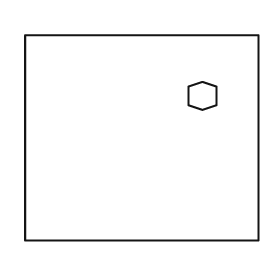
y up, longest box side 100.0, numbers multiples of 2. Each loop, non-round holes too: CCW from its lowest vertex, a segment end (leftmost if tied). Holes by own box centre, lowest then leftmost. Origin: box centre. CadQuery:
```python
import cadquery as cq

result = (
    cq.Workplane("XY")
    .moveTo(-50.0, -44.0)
    .lineTo(50.0, -44.0)
    .lineTo(50.0, 44.0)
    .lineTo(-50.0, 44.0)
    .close()
    .moveTo(26.0, 12.0)
    .lineTo(32.0, 14.0)
    .lineTo(32.0, 22.0)
    .lineTo(26.0, 24.0)
    .lineTo(20.0, 22.0)
    .lineTo(20.0, 14.0)
    .close()
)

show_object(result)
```